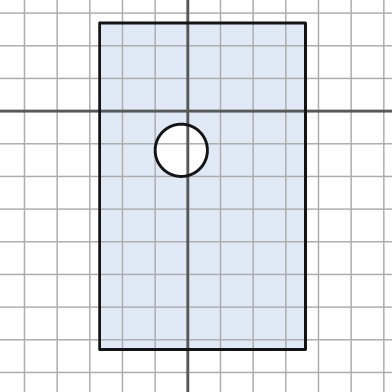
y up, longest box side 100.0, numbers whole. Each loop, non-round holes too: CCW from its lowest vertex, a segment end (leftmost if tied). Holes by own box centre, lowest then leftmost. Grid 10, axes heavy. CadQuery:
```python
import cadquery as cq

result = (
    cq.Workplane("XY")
    .moveTo(-27.0, -73.0)
    .lineTo(36.0, -73.0)
    .lineTo(36.0, 27.0)
    .lineTo(-27.0, 27.0)
    .close()
    .moveTo(-2.0, -12.0)
    .circle(8.0)
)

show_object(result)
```